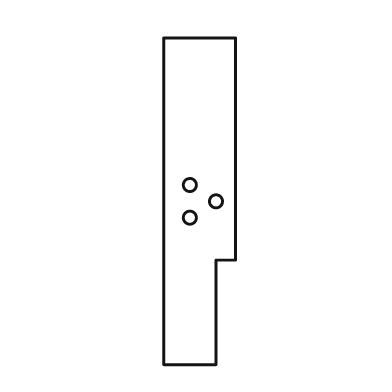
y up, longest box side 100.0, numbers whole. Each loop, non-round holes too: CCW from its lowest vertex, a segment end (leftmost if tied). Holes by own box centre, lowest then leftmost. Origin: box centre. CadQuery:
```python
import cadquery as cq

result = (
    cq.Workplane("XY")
    .moveTo(-11.0, -50.0)
    .lineTo(5.0, -50.0)
    .lineTo(5.0, -18.0)
    .lineTo(11.0, -18.0)
    .lineTo(11.0, 50.0)
    .lineTo(-11.0, 50.0)
    .close()
    .moveTo(-3.0, -5.0)
    .circle(2.0)
    .moveTo(5.0, 0.0)
    .circle(2.0)
    .moveTo(-3.0, 5.0)
    .circle(2.0)
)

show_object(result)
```